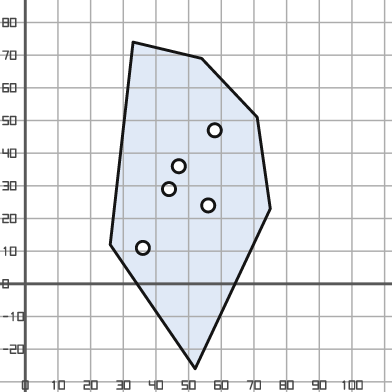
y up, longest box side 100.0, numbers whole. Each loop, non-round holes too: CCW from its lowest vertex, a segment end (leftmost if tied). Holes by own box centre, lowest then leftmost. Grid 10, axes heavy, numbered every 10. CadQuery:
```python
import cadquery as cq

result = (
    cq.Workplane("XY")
    .moveTo(52.0, -26.0)
    .lineTo(75.0, 23.0)
    .lineTo(71.0, 51.0)
    .lineTo(54.0, 69.0)
    .lineTo(33.0, 74.0)
    .lineTo(26.0, 12.0)
    .close()
    .moveTo(36.0, 11.0)
    .circle(2.0)
    .moveTo(56.0, 24.0)
    .circle(2.0)
    .moveTo(44.0, 29.0)
    .circle(2.0)
    .moveTo(47.0, 36.0)
    .circle(2.0)
    .moveTo(58.0, 47.0)
    .circle(2.0)
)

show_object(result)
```